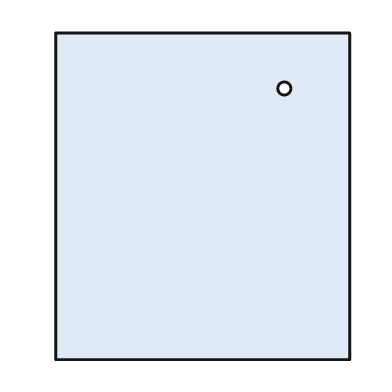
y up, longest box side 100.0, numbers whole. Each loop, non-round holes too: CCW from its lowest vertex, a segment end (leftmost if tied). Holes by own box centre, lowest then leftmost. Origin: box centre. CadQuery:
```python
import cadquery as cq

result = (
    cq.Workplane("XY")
    .moveTo(-45.0, -50.0)
    .lineTo(45.0, -50.0)
    .lineTo(45.0, 50.0)
    .lineTo(-45.0, 50.0)
    .close()
    .moveTo(25.0, 33.0)
    .circle(2.0)
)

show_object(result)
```